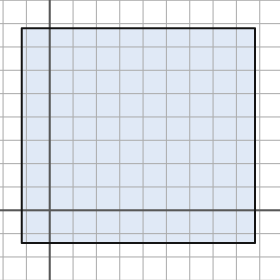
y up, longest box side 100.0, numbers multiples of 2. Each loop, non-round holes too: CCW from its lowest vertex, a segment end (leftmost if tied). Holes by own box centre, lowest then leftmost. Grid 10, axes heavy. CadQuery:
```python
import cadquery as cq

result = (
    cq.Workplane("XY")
    .moveTo(-12.0, -14.0)
    .lineTo(88.0, -14.0)
    .lineTo(88.0, 78.0)
    .lineTo(-12.0, 78.0)
    .close()
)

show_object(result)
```